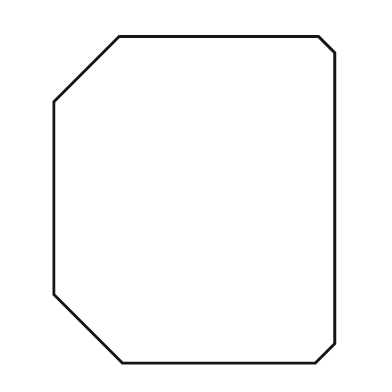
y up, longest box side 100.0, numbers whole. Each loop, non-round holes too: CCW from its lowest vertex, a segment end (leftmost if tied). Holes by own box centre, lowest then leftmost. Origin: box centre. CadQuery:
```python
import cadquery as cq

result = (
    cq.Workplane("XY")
    .moveTo(-22.0, -50.0)
    .lineTo(37.0, -50.0)
    .lineTo(43.0, -44.0)
    .lineTo(43.0, 45.0)
    .lineTo(38.0, 50.0)
    .lineTo(-23.0, 50.0)
    .lineTo(-43.0, 30.0)
    .lineTo(-43.0, -29.0)
    .close()
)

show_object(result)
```